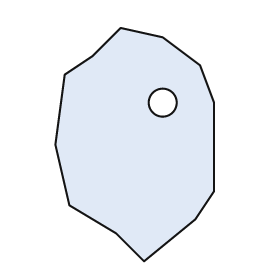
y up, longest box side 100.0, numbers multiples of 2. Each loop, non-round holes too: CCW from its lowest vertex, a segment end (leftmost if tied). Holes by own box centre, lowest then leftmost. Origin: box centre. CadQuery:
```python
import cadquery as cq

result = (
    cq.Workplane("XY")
    .moveTo(4.0, -50.0)
    .lineTo(26.0, -32.0)
    .lineTo(34.0, -20.0)
    .lineTo(34.0, 18.0)
    .lineTo(28.0, 34.0)
    .lineTo(12.0, 46.0)
    .lineTo(-6.0, 50.0)
    .lineTo(-18.0, 38.0)
    .lineTo(-30.0, 30.0)
    .lineTo(-34.0, 0.0)
    .lineTo(-28.0, -26.0)
    .lineTo(-8.0, -38.0)
    .close()
    .moveTo(12.0, 18.0)
    .circle(6.0)
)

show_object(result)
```